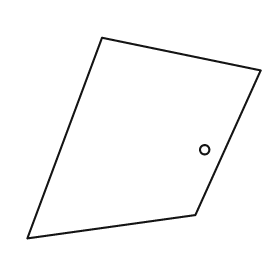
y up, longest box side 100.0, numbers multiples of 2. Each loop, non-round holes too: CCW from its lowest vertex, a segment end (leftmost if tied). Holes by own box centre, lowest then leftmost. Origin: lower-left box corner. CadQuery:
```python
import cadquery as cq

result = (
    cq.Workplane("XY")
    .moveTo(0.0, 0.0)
    .lineTo(72.0, 10.0)
    .lineTo(100.0, 72.0)
    .lineTo(32.0, 86.0)
    .close()
    .moveTo(76.0, 38.0)
    .circle(2.0)
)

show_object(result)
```